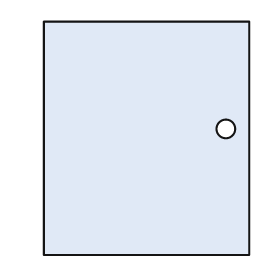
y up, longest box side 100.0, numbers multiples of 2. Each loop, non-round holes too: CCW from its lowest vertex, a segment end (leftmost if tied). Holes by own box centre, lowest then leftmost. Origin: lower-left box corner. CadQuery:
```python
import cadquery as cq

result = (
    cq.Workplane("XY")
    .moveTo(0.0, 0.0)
    .lineTo(88.0, 0.0)
    .lineTo(88.0, 100.0)
    .lineTo(0.0, 100.0)
    .close()
    .moveTo(78.0, 54.0)
    .circle(4.0)
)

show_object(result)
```